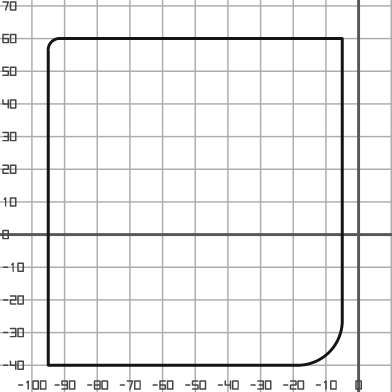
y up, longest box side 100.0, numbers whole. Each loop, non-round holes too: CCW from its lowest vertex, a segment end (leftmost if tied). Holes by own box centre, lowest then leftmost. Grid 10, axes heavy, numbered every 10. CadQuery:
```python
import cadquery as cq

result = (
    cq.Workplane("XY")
    .moveTo(-95.0, -40.0)
    .lineTo(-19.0, -40.0)
    .threePointArc((-9.0, -36.0), (-5.0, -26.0))
    .lineTo(-5.0, 60.0)
    .lineTo(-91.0, 60.0)
    .threePointArc((-94.0, 59.0), (-95.0, 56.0))
    .close()
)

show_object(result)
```